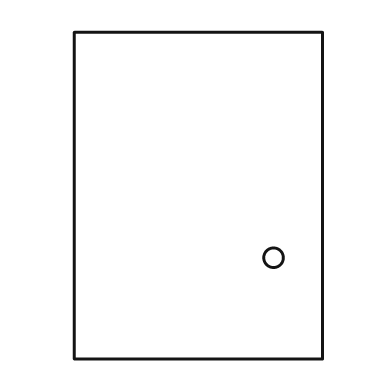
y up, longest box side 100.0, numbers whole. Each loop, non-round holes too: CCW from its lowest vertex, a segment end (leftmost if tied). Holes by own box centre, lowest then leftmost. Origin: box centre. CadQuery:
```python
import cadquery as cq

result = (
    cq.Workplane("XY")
    .moveTo(-38.0, -50.0)
    .lineTo(38.0, -50.0)
    .lineTo(38.0, 50.0)
    .lineTo(-38.0, 50.0)
    .close()
    .moveTo(23.0, -19.0)
    .circle(3.0)
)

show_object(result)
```